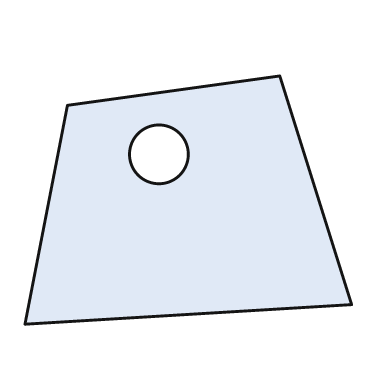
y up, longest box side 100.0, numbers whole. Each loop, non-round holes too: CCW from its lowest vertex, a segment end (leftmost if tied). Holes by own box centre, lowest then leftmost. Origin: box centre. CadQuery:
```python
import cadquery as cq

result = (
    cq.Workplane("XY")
    .moveTo(-50.0, -38.0)
    .lineTo(50.0, -32.0)
    .lineTo(28.0, 38.0)
    .lineTo(-37.0, 29.0)
    .close()
    .moveTo(-9.0, 14.0)
    .circle(9.0)
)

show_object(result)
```